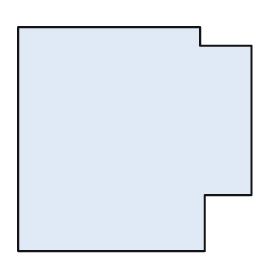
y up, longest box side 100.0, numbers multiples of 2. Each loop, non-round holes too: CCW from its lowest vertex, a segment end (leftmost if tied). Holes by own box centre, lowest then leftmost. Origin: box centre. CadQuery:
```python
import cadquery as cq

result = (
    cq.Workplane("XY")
    .moveTo(-50.0, -48.0)
    .lineTo(30.0, -48.0)
    .lineTo(30.0, -24.0)
    .lineTo(50.0, -24.0)
    .lineTo(50.0, 40.0)
    .lineTo(28.0, 40.0)
    .lineTo(28.0, 48.0)
    .lineTo(-50.0, 48.0)
    .close()
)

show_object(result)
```